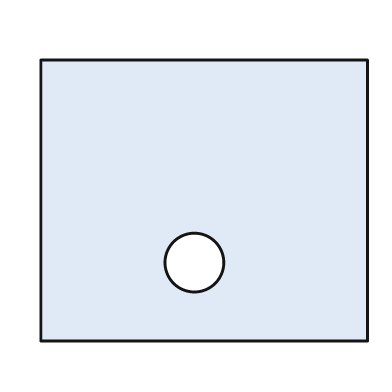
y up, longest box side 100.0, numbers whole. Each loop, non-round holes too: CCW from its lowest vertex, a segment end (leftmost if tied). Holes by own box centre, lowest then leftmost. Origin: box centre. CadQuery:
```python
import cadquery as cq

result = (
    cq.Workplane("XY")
    .moveTo(-50.0, -43.0)
    .lineTo(50.0, -43.0)
    .lineTo(50.0, 43.0)
    .lineTo(-50.0, 43.0)
    .close()
    .moveTo(-3.0, -19.0)
    .circle(9.0)
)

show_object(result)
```